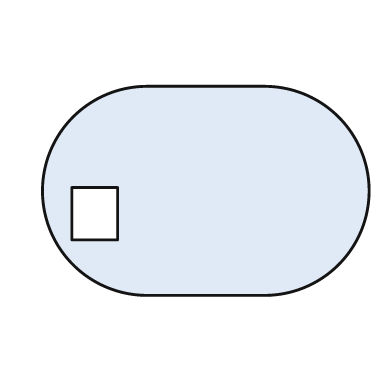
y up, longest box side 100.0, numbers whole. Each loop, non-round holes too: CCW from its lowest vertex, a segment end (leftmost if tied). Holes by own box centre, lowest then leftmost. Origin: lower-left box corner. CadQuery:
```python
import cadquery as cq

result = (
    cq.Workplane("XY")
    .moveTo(32.0, 0.0)
    .lineTo(68.0, 0.0)
    .threePointArc((100.0, 32.0), (68.0, 64.0))
    .lineTo(32.0, 64.0)
    .threePointArc((0.0, 32.0), (32.0, 0.0))
    .close()
    .moveTo(9.0, 17.0)
    .lineTo(23.0, 17.0)
    .lineTo(23.0, 33.0)
    .lineTo(9.0, 33.0)
    .close()
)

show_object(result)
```